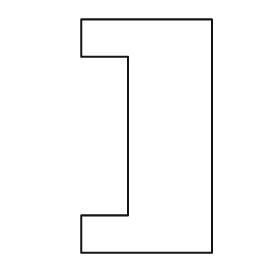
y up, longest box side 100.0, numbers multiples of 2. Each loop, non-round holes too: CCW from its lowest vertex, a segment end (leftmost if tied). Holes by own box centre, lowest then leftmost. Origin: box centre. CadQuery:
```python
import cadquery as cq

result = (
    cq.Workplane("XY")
    .moveTo(-28.0, -50.0)
    .lineTo(28.0, -50.0)
    .lineTo(28.0, 50.0)
    .lineTo(-28.0, 50.0)
    .lineTo(-28.0, 34.0)
    .lineTo(-8.0, 34.0)
    .lineTo(-8.0, -34.0)
    .lineTo(-28.0, -34.0)
    .close()
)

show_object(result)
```